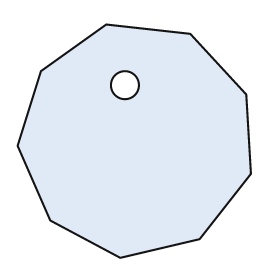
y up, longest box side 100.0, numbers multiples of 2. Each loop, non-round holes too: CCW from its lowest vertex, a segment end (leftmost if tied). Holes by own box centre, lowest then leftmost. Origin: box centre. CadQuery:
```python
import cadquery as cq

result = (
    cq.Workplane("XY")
    .moveTo(-6.0, -50.0)
    .lineTo(28.0, -42.0)
    .lineTo(50.0, -14.0)
    .lineTo(48.0, 20.0)
    .lineTo(24.0, 46.0)
    .lineTo(-12.0, 50.0)
    .lineTo(-40.0, 30.0)
    .lineTo(-50.0, -2.0)
    .lineTo(-36.0, -34.0)
    .close()
    .moveTo(-4.0, 24.0)
    .circle(6.0)
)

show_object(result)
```